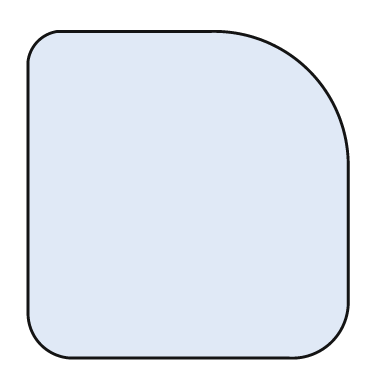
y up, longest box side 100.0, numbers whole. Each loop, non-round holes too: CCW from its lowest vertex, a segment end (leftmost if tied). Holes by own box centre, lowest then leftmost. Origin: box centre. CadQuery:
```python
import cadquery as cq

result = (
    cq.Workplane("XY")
    .moveTo(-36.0, -50.0)
    .lineTo(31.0, -50.0)
    .threePointArc((44.0, -45.0), (49.0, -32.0))
    .lineTo(49.0, 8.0)
    .threePointArc((37.0, 38.0), (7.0, 50.0))
    .lineTo(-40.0, 50.0)
    .threePointArc((-46.0, 47.0), (-49.0, 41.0))
    .lineTo(-49.0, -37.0)
    .threePointArc((-45.0, -46.0), (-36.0, -50.0))
    .close()
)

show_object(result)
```